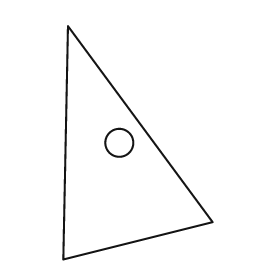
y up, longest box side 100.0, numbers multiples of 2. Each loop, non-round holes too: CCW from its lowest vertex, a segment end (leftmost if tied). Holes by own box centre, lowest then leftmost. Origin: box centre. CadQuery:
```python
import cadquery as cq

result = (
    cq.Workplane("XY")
    .moveTo(-32.0, -50.0)
    .lineTo(32.0, -34.0)
    .lineTo(-30.0, 50.0)
    .close()
    .moveTo(-8.0, 0.0)
    .circle(6.0)
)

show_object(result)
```